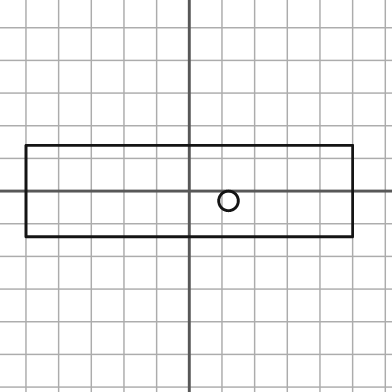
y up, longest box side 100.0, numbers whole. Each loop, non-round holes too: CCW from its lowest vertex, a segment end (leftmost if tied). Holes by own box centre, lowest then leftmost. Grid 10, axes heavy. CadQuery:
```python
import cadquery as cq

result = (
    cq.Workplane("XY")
    .moveTo(-50.0, -14.0)
    .lineTo(50.0, -14.0)
    .lineTo(50.0, 14.0)
    .lineTo(-50.0, 14.0)
    .close()
    .moveTo(12.0, -3.0)
    .circle(3.0)
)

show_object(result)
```